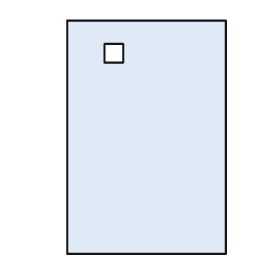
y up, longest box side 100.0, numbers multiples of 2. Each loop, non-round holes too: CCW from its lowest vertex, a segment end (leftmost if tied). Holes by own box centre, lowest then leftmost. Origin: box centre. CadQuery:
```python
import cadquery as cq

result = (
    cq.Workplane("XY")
    .moveTo(-34.0, -50.0)
    .lineTo(34.0, -50.0)
    .lineTo(34.0, 50.0)
    .lineTo(-34.0, 50.0)
    .close()
    .moveTo(-18.0, 32.0)
    .lineTo(-10.0, 32.0)
    .lineTo(-10.0, 40.0)
    .lineTo(-18.0, 40.0)
    .close()
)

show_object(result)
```